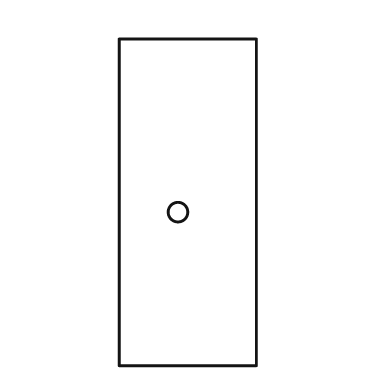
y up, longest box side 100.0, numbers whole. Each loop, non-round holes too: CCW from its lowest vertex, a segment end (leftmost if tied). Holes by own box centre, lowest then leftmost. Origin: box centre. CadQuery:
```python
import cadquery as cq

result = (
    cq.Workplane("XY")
    .moveTo(-21.0, -50.0)
    .lineTo(21.0, -50.0)
    .lineTo(21.0, 50.0)
    .lineTo(-21.0, 50.0)
    .close()
    .moveTo(-3.0, -3.0)
    .circle(3.0)
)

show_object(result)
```